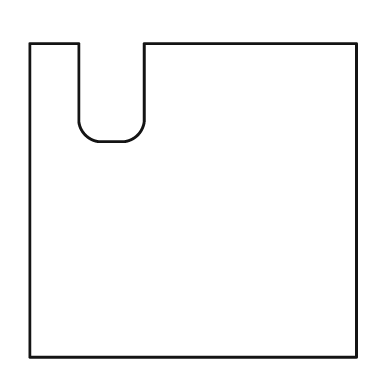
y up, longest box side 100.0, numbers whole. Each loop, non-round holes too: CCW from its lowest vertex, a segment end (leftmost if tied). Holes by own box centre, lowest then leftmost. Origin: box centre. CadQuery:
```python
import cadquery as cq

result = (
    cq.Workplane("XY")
    .moveTo(-50.0, -48.0)
    .lineTo(50.0, -48.0)
    .lineTo(50.0, 48.0)
    .lineTo(-15.0, 48.0)
    .lineTo(-15.0, 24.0)
    .threePointArc((-17.0, 20.0), (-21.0, 18.0))
    .lineTo(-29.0, 18.0)
    .threePointArc((-33.0, 20.0), (-35.0, 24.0))
    .lineTo(-35.0, 48.0)
    .lineTo(-50.0, 48.0)
    .close()
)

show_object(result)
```